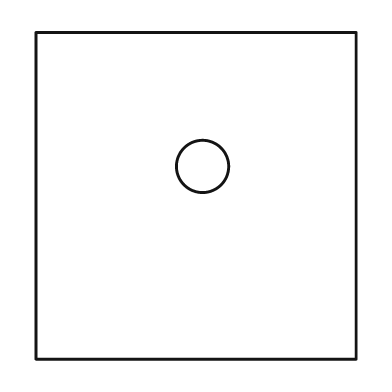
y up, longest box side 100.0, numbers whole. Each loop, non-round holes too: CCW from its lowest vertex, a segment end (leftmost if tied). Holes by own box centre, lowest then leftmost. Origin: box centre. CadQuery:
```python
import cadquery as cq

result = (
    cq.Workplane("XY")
    .moveTo(-49.0, -50.0)
    .lineTo(49.0, -50.0)
    .lineTo(49.0, 50.0)
    .lineTo(-49.0, 50.0)
    .close()
    .moveTo(2.0, 9.0)
    .circle(8.0)
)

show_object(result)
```